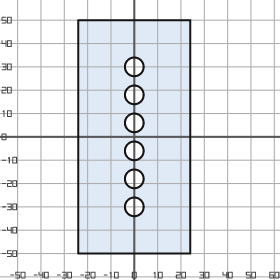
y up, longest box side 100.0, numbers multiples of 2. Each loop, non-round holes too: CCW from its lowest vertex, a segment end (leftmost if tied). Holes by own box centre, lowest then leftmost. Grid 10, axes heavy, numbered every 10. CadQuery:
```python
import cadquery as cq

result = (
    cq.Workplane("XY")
    .moveTo(-24.0, -50.0)
    .lineTo(24.0, -50.0)
    .lineTo(24.0, 50.0)
    .lineTo(-24.0, 50.0)
    .close()
    .moveTo(0.0, -30.0)
    .circle(4.0)
    .moveTo(0.0, -18.0)
    .circle(4.0)
    .moveTo(0.0, -6.0)
    .circle(4.0)
    .moveTo(0.0, 6.0)
    .circle(4.0)
    .moveTo(0.0, 18.0)
    .circle(4.0)
    .moveTo(0.0, 30.0)
    .circle(4.0)
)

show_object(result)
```